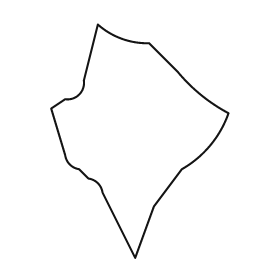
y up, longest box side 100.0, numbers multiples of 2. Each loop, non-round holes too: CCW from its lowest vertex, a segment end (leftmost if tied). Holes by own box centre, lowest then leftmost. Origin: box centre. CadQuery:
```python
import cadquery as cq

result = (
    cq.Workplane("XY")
    .moveTo(-2.0, -50.0)
    .lineTo(6.0, -28.0)
    .lineTo(18.0, -12.0)
    .threePointArc((30.0, -2.0), (38.0, 12.0))
    .threePointArc((26.0, 20.0), (16.0, 30.0))
    .lineTo(4.0, 42.0)
    .threePointArc((-8.0, 44.0), (-18.0, 50.0))
    .lineTo(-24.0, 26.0)
    .threePointArc((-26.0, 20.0), (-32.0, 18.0))
    .lineTo(-38.0, 14.0)
    .lineTo(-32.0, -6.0)
    .threePointArc((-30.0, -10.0), (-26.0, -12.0))
    .lineTo(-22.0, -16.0)
    .threePointArc((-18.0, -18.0), (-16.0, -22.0))
    .close()
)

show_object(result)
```